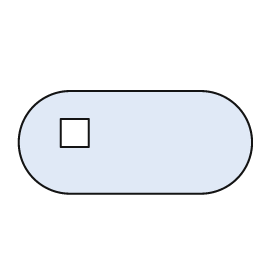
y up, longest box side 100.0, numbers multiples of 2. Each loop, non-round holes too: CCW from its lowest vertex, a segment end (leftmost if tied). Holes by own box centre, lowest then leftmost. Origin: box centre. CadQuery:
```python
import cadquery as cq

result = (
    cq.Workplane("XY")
    .moveTo(-28.0, -22.0)
    .lineTo(28.0, -22.0)
    .threePointArc((50.0, 0.0), (28.0, 22.0))
    .lineTo(-28.0, 22.0)
    .threePointArc((-50.0, 0.0), (-28.0, -22.0))
    .close()
    .moveTo(-32.0, -2.0)
    .lineTo(-20.0, -2.0)
    .lineTo(-20.0, 10.0)
    .lineTo(-32.0, 10.0)
    .close()
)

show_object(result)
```